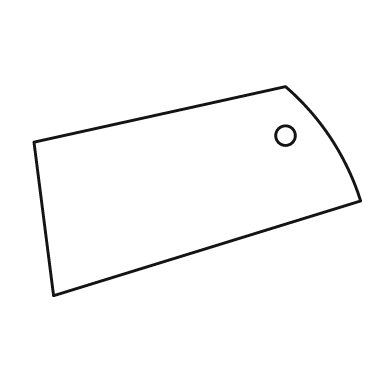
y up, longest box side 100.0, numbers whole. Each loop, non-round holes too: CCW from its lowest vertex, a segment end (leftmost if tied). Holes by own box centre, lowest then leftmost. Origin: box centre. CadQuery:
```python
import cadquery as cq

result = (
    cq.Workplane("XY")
    .moveTo(-44.0, -32.0)
    .lineTo(50.0, -3.0)
    .threePointArc((41.0, 16.0), (27.0, 32.0))
    .lineTo(-50.0, 15.0)
    .close()
    .moveTo(27.0, 17.0)
    .circle(3.0)
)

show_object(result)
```